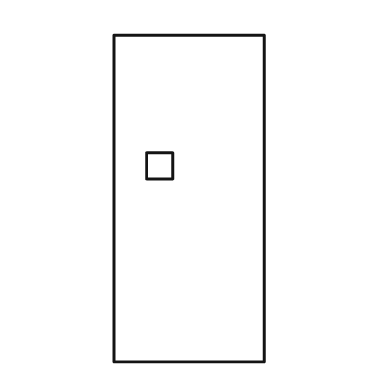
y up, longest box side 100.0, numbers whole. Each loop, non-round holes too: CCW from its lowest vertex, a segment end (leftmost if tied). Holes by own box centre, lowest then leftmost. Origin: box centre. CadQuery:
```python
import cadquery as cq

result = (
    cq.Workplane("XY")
    .moveTo(-23.0, -50.0)
    .lineTo(23.0, -50.0)
    .lineTo(23.0, 50.0)
    .lineTo(-23.0, 50.0)
    .close()
    .moveTo(-13.0, 6.0)
    .lineTo(-5.0, 6.0)
    .lineTo(-5.0, 14.0)
    .lineTo(-13.0, 14.0)
    .close()
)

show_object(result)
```